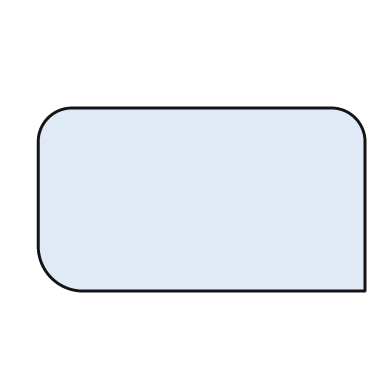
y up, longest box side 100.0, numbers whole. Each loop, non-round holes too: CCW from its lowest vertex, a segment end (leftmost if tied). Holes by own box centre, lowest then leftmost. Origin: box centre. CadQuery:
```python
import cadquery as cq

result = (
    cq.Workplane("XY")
    .moveTo(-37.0, -28.0)
    .lineTo(50.0, -28.0)
    .lineTo(50.0, 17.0)
    .threePointArc((47.0, 25.0), (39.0, 28.0))
    .lineTo(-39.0, 28.0)
    .threePointArc((-47.0, 25.0), (-50.0, 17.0))
    .lineTo(-50.0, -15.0)
    .threePointArc((-46.0, -24.0), (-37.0, -28.0))
    .close()
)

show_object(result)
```